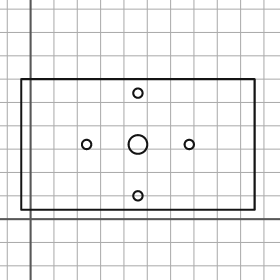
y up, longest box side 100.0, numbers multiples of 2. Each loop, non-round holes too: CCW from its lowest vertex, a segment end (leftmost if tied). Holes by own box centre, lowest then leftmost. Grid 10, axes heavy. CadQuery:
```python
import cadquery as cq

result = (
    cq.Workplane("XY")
    .moveTo(-4.0, 4.0)
    .lineTo(96.0, 4.0)
    .lineTo(96.0, 60.0)
    .lineTo(-4.0, 60.0)
    .close()
    .moveTo(46.0, 10.0)
    .circle(2.0)
    .moveTo(24.0, 32.0)
    .circle(2.0)
    .moveTo(46.0, 32.0)
    .circle(4.0)
    .moveTo(68.0, 32.0)
    .circle(2.0)
    .moveTo(46.0, 54.0)
    .circle(2.0)
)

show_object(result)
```